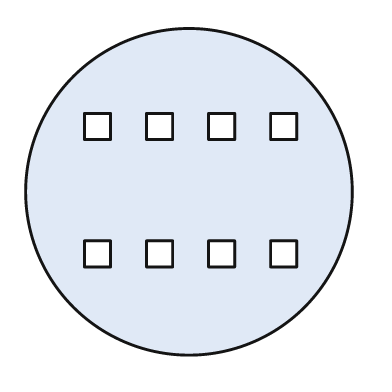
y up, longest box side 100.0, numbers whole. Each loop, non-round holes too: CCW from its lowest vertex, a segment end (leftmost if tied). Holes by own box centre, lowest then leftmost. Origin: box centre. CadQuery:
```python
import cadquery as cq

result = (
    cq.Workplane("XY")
    .moveTo(0.0, 0.0)
    .circle(50.0)
    .moveTo(-32.0, -23.0)
    .lineTo(-24.0, -23.0)
    .lineTo(-24.0, -15.0)
    .lineTo(-32.0, -15.0)
    .close()
    .moveTo(-13.0, -23.0)
    .lineTo(-5.0, -23.0)
    .lineTo(-5.0, -15.0)
    .lineTo(-13.0, -15.0)
    .close()
    .moveTo(6.0, -23.0)
    .lineTo(14.0, -23.0)
    .lineTo(14.0, -15.0)
    .lineTo(6.0, -15.0)
    .close()
    .moveTo(25.0, -23.0)
    .lineTo(33.0, -23.0)
    .lineTo(33.0, -15.0)
    .lineTo(25.0, -15.0)
    .close()
    .moveTo(-32.0, 16.0)
    .lineTo(-24.0, 16.0)
    .lineTo(-24.0, 24.0)
    .lineTo(-32.0, 24.0)
    .close()
    .moveTo(-13.0, 16.0)
    .lineTo(-5.0, 16.0)
    .lineTo(-5.0, 24.0)
    .lineTo(-13.0, 24.0)
    .close()
    .moveTo(6.0, 16.0)
    .lineTo(14.0, 16.0)
    .lineTo(14.0, 24.0)
    .lineTo(6.0, 24.0)
    .close()
    .moveTo(25.0, 16.0)
    .lineTo(33.0, 16.0)
    .lineTo(33.0, 24.0)
    .lineTo(25.0, 24.0)
    .close()
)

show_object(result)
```